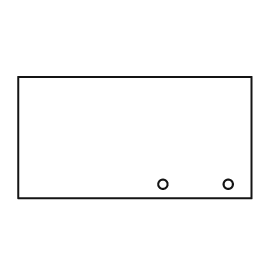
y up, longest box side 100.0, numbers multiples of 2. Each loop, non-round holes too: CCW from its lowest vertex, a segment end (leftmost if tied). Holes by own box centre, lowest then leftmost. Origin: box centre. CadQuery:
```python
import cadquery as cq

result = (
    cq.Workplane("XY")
    .moveTo(-50.0, -26.0)
    .lineTo(50.0, -26.0)
    .lineTo(50.0, 26.0)
    .lineTo(-50.0, 26.0)
    .close()
    .moveTo(12.0, -20.0)
    .circle(2.0)
    .moveTo(40.0, -20.0)
    .circle(2.0)
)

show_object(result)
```